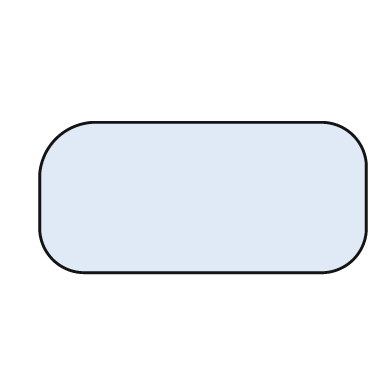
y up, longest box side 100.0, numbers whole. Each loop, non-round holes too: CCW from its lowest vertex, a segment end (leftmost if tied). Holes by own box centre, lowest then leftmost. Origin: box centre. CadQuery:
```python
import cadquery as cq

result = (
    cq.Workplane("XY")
    .moveTo(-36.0, -23.0)
    .lineTo(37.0, -23.0)
    .threePointArc((46.0, -19.0), (50.0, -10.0))
    .lineTo(50.0, 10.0)
    .threePointArc((46.0, 19.0), (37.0, 23.0))
    .lineTo(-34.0, 23.0)
    .threePointArc((-45.0, 18.0), (-50.0, 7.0))
    .lineTo(-50.0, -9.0)
    .threePointArc((-46.0, -19.0), (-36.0, -23.0))
    .close()
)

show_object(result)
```